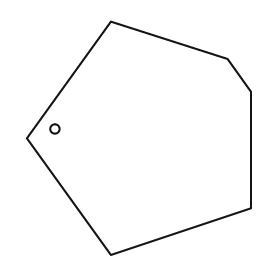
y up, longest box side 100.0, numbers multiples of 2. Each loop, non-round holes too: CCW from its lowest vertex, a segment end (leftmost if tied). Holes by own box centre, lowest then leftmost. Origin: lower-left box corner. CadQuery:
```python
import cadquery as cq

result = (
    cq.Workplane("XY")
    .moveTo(36.0, 0.0)
    .lineTo(96.0, 20.0)
    .lineTo(96.0, 70.0)
    .lineTo(86.0, 84.0)
    .lineTo(36.0, 100.0)
    .lineTo(0.0, 50.0)
    .close()
    .moveTo(12.0, 54.0)
    .circle(2.0)
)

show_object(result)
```